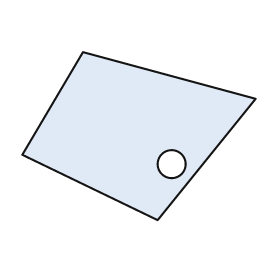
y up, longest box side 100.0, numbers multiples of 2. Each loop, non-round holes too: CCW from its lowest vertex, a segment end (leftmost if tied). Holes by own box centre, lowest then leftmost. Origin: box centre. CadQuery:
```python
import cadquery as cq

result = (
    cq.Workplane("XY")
    .moveTo(8.0, -36.0)
    .lineTo(50.0, 16.0)
    .lineTo(-24.0, 36.0)
    .lineTo(-50.0, -8.0)
    .close()
    .moveTo(14.0, -12.0)
    .circle(6.0)
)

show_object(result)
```